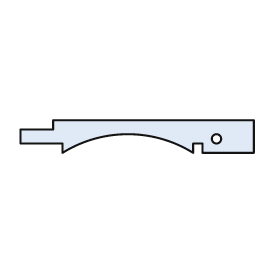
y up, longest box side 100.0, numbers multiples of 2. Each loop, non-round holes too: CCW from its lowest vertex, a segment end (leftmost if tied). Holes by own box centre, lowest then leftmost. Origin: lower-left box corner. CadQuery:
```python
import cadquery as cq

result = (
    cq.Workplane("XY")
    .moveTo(18.0, 0.0)
    .threePointArc((46.0, 8.0), (74.0, 0.0))
    .lineTo(74.0, 4.0)
    .lineTo(78.0, 4.0)
    .lineTo(78.0, 0.0)
    .lineTo(100.0, 0.0)
    .lineTo(100.0, 14.0)
    .lineTo(14.0, 14.0)
    .lineTo(14.0, 10.0)
    .lineTo(0.0, 10.0)
    .lineTo(0.0, 4.0)
    .lineTo(18.0, 4.0)
    .close()
    .moveTo(84.0, 6.0)
    .circle(2.0)
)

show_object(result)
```